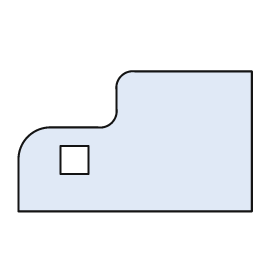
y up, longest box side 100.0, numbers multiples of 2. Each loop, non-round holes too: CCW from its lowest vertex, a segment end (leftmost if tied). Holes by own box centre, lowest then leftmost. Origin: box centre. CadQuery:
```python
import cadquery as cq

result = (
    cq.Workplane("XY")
    .moveTo(-50.0, -30.0)
    .lineTo(50.0, -30.0)
    .lineTo(50.0, 30.0)
    .lineTo(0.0, 30.0)
    .threePointArc((-6.0, 28.0), (-8.0, 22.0))
    .lineTo(-8.0, 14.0)
    .threePointArc((-10.0, 8.0), (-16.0, 6.0))
    .lineTo(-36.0, 6.0)
    .threePointArc((-46.0, 2.0), (-50.0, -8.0))
    .close()
    .moveTo(-32.0, -14.0)
    .lineTo(-20.0, -14.0)
    .lineTo(-20.0, -2.0)
    .lineTo(-32.0, -2.0)
    .close()
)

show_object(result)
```